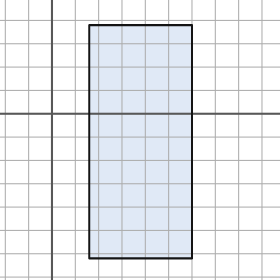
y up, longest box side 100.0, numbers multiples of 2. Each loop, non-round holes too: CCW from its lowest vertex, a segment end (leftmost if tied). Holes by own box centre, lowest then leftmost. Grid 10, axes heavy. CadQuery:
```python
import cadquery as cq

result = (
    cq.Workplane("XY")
    .moveTo(16.0, -62.0)
    .lineTo(60.0, -62.0)
    .lineTo(60.0, 38.0)
    .lineTo(16.0, 38.0)
    .close()
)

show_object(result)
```